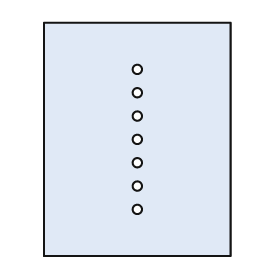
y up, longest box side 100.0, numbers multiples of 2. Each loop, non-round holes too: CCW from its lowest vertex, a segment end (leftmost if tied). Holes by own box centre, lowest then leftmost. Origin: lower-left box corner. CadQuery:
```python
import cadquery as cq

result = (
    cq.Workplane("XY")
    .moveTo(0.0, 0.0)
    .lineTo(80.0, 0.0)
    .lineTo(80.0, 100.0)
    .lineTo(0.0, 100.0)
    .close()
    .moveTo(40.0, 20.0)
    .circle(2.0)
    .moveTo(40.0, 30.0)
    .circle(2.0)
    .moveTo(40.0, 40.0)
    .circle(2.0)
    .moveTo(40.0, 50.0)
    .circle(2.0)
    .moveTo(40.0, 60.0)
    .circle(2.0)
    .moveTo(40.0, 70.0)
    .circle(2.0)
    .moveTo(40.0, 80.0)
    .circle(2.0)
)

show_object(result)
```